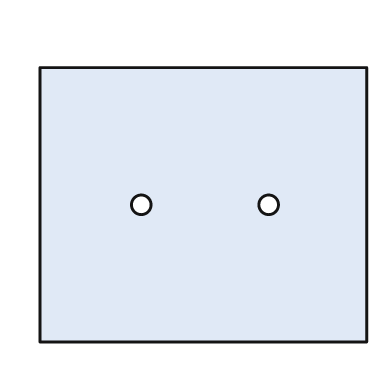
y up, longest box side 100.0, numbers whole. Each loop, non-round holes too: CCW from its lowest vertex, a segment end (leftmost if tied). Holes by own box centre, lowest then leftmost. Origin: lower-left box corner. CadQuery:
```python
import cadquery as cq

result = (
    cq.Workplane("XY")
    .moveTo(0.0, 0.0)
    .lineTo(100.0, 0.0)
    .lineTo(100.0, 84.0)
    .lineTo(0.0, 84.0)
    .close()
    .moveTo(31.0, 42.0)
    .circle(3.0)
    .moveTo(70.0, 42.0)
    .circle(3.0)
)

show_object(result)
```